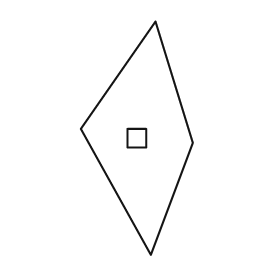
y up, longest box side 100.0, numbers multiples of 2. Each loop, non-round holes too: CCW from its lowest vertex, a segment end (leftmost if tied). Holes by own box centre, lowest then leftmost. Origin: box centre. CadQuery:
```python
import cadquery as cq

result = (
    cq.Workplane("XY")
    .moveTo(6.0, -50.0)
    .lineTo(24.0, -2.0)
    .lineTo(8.0, 50.0)
    .lineTo(-24.0, 4.0)
    .close()
    .moveTo(-4.0, -4.0)
    .lineTo(4.0, -4.0)
    .lineTo(4.0, 4.0)
    .lineTo(-4.0, 4.0)
    .close()
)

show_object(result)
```